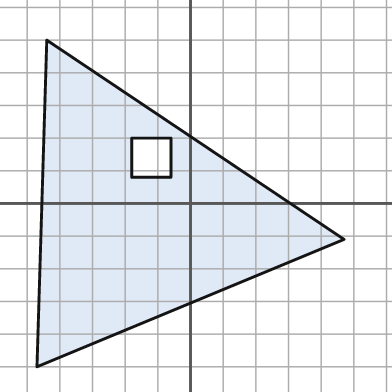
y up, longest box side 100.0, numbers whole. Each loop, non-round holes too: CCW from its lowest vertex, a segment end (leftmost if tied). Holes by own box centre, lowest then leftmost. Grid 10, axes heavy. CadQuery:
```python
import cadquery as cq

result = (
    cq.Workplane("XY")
    .moveTo(-47.0, -50.0)
    .lineTo(47.0, -11.0)
    .lineTo(-44.0, 50.0)
    .close()
    .moveTo(-18.0, 8.0)
    .lineTo(-6.0, 8.0)
    .lineTo(-6.0, 20.0)
    .lineTo(-18.0, 20.0)
    .close()
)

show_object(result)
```